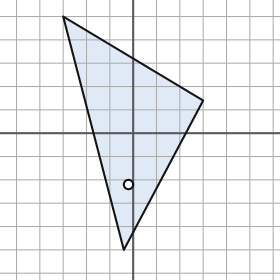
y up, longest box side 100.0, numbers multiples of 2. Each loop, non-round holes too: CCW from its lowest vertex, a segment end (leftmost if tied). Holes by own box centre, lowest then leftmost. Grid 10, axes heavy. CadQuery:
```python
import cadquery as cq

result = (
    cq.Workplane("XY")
    .moveTo(-4.0, -50.0)
    .lineTo(30.0, 14.0)
    .lineTo(-30.0, 50.0)
    .close()
    .moveTo(-2.0, -22.0)
    .circle(2.0)
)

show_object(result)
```